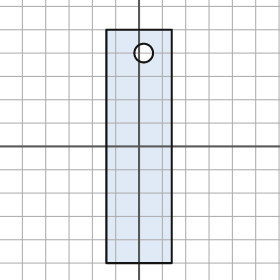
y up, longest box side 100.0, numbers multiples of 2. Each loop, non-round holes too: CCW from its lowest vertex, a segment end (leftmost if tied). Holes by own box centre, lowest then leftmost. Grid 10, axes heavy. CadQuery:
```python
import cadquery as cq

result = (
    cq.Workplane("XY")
    .moveTo(-14.0, -50.0)
    .lineTo(14.0, -50.0)
    .lineTo(14.0, 50.0)
    .lineTo(-14.0, 50.0)
    .close()
    .moveTo(2.0, 40.0)
    .circle(4.0)
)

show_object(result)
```